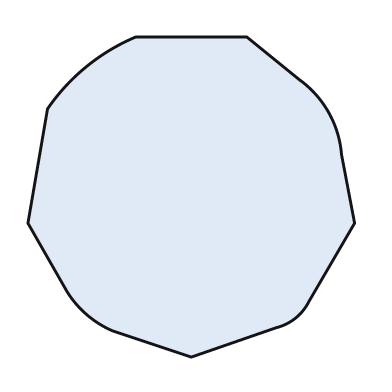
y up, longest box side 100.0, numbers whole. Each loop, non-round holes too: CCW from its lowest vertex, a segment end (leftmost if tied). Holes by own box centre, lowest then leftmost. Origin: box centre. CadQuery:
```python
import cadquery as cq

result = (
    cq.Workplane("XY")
    .moveTo(0.0, -49.0)
    .lineTo(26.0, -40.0)
    .threePointArc((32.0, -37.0), (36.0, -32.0))
    .lineTo(50.0, -8.0)
    .lineTo(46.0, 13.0)
    .threePointArc((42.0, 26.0), (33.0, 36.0))
    .lineTo(17.0, 49.0)
    .lineTo(-17.0, 49.0)
    .threePointArc((-32.0, 40.0), (-44.0, 27.0))
    .lineTo(-50.0, -8.0)
    .lineTo(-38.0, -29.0)
    .threePointArc((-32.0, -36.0), (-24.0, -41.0))
    .close()
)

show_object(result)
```